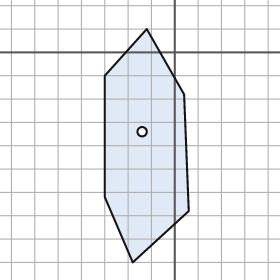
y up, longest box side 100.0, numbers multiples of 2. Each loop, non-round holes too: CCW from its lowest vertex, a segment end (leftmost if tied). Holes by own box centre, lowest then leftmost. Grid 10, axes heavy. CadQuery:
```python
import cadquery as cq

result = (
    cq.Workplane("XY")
    .moveTo(-18.0, -90.0)
    .lineTo(6.0, -68.0)
    .lineTo(4.0, -18.0)
    .lineTo(-12.0, 10.0)
    .lineTo(-30.0, -10.0)
    .lineTo(-30.0, -62.0)
    .close()
    .moveTo(-14.0, -34.0)
    .circle(2.0)
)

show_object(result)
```